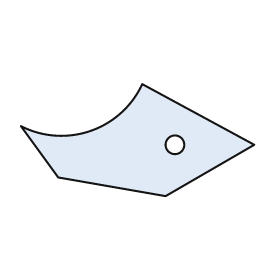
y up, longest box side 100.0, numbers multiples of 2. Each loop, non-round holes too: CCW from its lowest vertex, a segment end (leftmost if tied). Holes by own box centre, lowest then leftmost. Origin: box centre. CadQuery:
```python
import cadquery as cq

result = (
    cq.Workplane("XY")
    .moveTo(12.0, -24.0)
    .lineTo(50.0, -2.0)
    .lineTo(2.0, 24.0)
    .threePointArc((-20.0, 4.0), (-50.0, 6.0))
    .lineTo(-34.0, -16.0)
    .close()
    .moveTo(16.0, -2.0)
    .circle(4.0)
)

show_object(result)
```